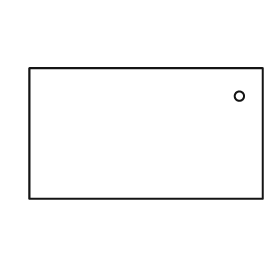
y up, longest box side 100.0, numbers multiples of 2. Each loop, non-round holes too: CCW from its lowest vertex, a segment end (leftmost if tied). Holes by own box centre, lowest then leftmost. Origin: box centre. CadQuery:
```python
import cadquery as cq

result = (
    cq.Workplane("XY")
    .moveTo(-50.0, -28.0)
    .lineTo(50.0, -28.0)
    .lineTo(50.0, 28.0)
    .lineTo(-50.0, 28.0)
    .close()
    .moveTo(40.0, 16.0)
    .circle(2.0)
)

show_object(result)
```